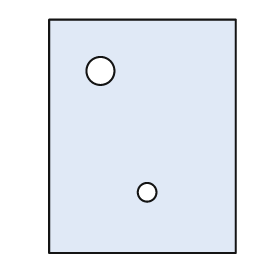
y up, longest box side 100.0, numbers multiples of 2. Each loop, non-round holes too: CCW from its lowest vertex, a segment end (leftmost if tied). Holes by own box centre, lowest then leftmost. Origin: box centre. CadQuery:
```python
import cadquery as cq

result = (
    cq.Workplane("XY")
    .moveTo(-40.0, -50.0)
    .lineTo(40.0, -50.0)
    .lineTo(40.0, 50.0)
    .lineTo(-40.0, 50.0)
    .close()
    .moveTo(2.0, -24.0)
    .circle(4.0)
    .moveTo(-18.0, 28.0)
    .circle(6.0)
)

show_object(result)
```